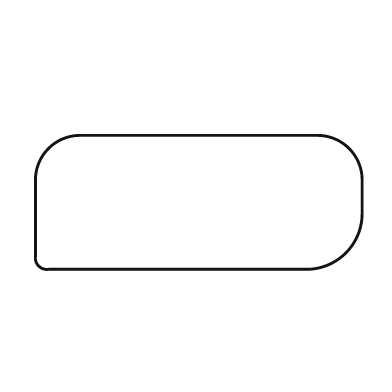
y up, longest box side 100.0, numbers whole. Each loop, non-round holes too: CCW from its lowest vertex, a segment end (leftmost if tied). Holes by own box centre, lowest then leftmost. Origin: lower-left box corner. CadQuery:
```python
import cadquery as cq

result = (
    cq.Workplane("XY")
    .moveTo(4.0, 0.0)
    .lineTo(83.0, 0.0)
    .threePointArc((95.0, 5.0), (100.0, 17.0))
    .lineTo(100.0, 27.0)
    .threePointArc((96.0, 37.0), (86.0, 41.0))
    .lineTo(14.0, 41.0)
    .threePointArc((4.0, 37.0), (0.0, 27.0))
    .lineTo(0.0, 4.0)
    .threePointArc((1.0, 1.0), (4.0, 0.0))
    .close()
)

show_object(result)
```